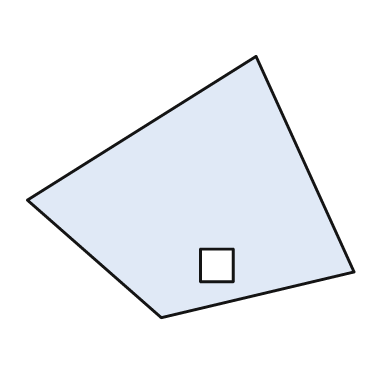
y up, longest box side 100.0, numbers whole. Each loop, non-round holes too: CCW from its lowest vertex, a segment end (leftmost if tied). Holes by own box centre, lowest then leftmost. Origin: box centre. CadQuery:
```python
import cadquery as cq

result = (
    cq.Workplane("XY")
    .moveTo(-9.0, -40.0)
    .lineTo(50.0, -26.0)
    .lineTo(20.0, 40.0)
    .lineTo(-50.0, -4.0)
    .close()
    .moveTo(3.0, -29.0)
    .lineTo(13.0, -29.0)
    .lineTo(13.0, -19.0)
    .lineTo(3.0, -19.0)
    .close()
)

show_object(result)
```